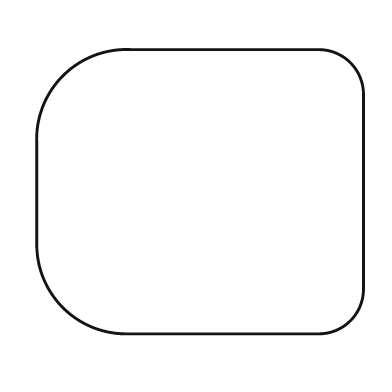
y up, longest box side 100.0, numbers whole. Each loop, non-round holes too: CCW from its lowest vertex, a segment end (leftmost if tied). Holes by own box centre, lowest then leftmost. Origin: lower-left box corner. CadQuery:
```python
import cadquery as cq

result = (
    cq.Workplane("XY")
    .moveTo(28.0, 0.0)
    .lineTo(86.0, 0.0)
    .threePointArc((96.0, 4.0), (100.0, 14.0))
    .lineTo(100.0, 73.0)
    .threePointArc((96.0, 83.0), (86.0, 87.0))
    .lineTo(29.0, 87.0)
    .threePointArc((8.0, 79.0), (0.0, 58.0))
    .lineTo(0.0, 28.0)
    .threePointArc((8.0, 8.0), (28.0, 0.0))
    .close()
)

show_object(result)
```